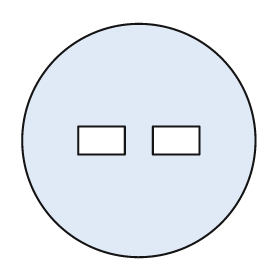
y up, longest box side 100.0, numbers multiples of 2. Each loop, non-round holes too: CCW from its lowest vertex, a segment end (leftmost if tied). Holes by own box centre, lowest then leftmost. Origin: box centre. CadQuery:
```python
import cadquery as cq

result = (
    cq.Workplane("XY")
    .moveTo(0.0, 0.0)
    .circle(50.0)
    .moveTo(-26.0, -6.0)
    .lineTo(-6.0, -6.0)
    .lineTo(-6.0, 6.0)
    .lineTo(-26.0, 6.0)
    .close()
    .moveTo(6.0, -6.0)
    .lineTo(26.0, -6.0)
    .lineTo(26.0, 6.0)
    .lineTo(6.0, 6.0)
    .close()
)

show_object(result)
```